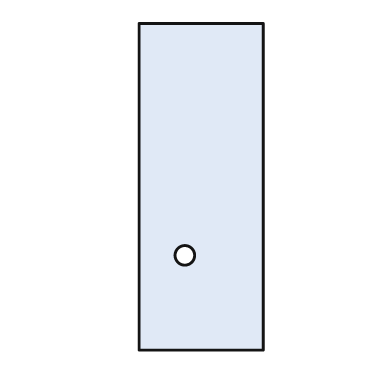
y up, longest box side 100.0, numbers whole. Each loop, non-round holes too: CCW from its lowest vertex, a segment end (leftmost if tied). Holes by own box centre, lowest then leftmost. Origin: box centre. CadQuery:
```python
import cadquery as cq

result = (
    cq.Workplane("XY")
    .moveTo(-19.0, -50.0)
    .lineTo(19.0, -50.0)
    .lineTo(19.0, 50.0)
    .lineTo(-19.0, 50.0)
    .close()
    .moveTo(-5.0, -21.0)
    .circle(3.0)
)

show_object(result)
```